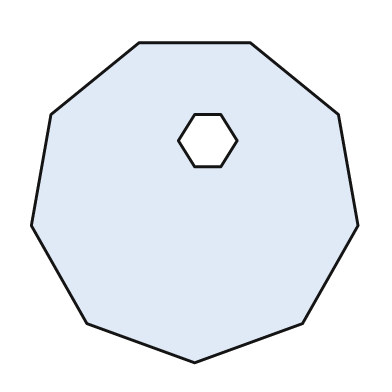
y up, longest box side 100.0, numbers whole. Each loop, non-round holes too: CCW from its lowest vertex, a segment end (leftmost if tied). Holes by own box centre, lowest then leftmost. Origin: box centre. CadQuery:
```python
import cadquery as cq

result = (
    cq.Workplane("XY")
    .moveTo(0.0, -49.0)
    .lineTo(33.0, -37.0)
    .lineTo(50.0, -7.0)
    .lineTo(44.0, 27.0)
    .lineTo(17.0, 49.0)
    .lineTo(-17.0, 49.0)
    .lineTo(-44.0, 27.0)
    .lineTo(-50.0, -7.0)
    .lineTo(-33.0, -37.0)
    .close()
    .moveTo(0.0, 11.0)
    .lineTo(8.0, 11.0)
    .lineTo(13.0, 19.0)
    .lineTo(8.0, 27.0)
    .lineTo(0.0, 27.0)
    .lineTo(-5.0, 19.0)
    .close()
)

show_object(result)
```